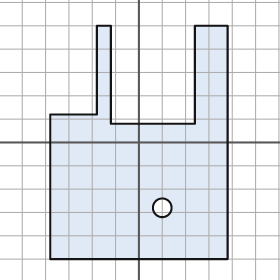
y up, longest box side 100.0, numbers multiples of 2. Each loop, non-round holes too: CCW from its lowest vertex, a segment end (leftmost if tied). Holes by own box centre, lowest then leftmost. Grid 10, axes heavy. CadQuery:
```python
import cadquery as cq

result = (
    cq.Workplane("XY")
    .moveTo(-38.0, -50.0)
    .lineTo(38.0, -50.0)
    .lineTo(38.0, 50.0)
    .lineTo(24.0, 50.0)
    .lineTo(24.0, 8.0)
    .lineTo(-12.0, 8.0)
    .lineTo(-12.0, 50.0)
    .lineTo(-18.0, 50.0)
    .lineTo(-18.0, 12.0)
    .lineTo(-38.0, 12.0)
    .close()
    .moveTo(10.0, -28.0)
    .circle(4.0)
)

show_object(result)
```